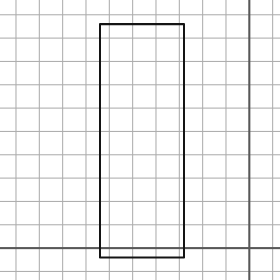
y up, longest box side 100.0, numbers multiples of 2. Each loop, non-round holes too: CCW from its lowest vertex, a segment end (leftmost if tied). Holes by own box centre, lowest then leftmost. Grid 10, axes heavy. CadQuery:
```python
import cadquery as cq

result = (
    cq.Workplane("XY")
    .moveTo(-64.0, -4.0)
    .lineTo(-28.0, -4.0)
    .lineTo(-28.0, 96.0)
    .lineTo(-64.0, 96.0)
    .close()
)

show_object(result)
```